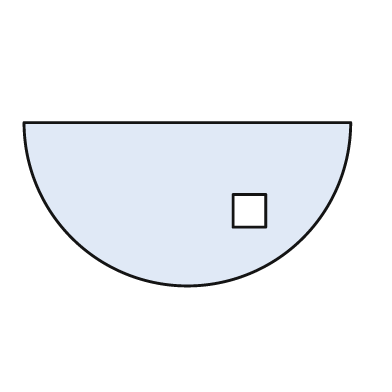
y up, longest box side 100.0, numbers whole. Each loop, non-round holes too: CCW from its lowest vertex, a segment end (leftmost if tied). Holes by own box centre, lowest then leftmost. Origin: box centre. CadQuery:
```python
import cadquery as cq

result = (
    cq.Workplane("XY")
    .moveTo(-50.0, 25.0)
    .threePointArc((0.0, -25.0), (50.0, 25.0))
    .close()
    .moveTo(14.0, -7.0)
    .lineTo(24.0, -7.0)
    .lineTo(24.0, 3.0)
    .lineTo(14.0, 3.0)
    .close()
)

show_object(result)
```